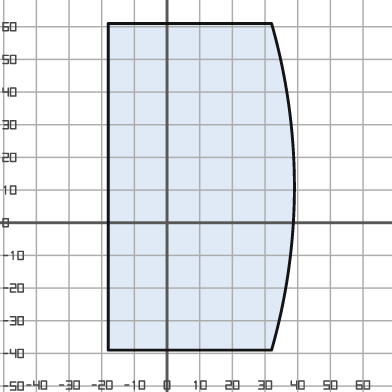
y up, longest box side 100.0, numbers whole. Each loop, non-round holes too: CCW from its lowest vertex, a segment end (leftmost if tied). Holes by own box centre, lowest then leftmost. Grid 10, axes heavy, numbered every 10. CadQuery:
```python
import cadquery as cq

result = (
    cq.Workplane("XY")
    .moveTo(-18.0, -39.0)
    .lineTo(32.0, -39.0)
    .threePointArc((39.0, 11.0), (32.0, 61.0))
    .lineTo(-18.0, 61.0)
    .close()
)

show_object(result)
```